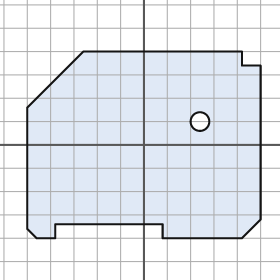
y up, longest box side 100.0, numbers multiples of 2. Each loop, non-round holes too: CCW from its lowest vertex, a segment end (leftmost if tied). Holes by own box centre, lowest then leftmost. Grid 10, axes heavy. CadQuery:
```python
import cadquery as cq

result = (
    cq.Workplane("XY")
    .moveTo(-46.0, -40.0)
    .lineTo(-38.0, -40.0)
    .lineTo(-38.0, -34.0)
    .lineTo(8.0, -34.0)
    .lineTo(8.0, -40.0)
    .lineTo(42.0, -40.0)
    .lineTo(50.0, -32.0)
    .lineTo(50.0, 34.0)
    .lineTo(42.0, 34.0)
    .lineTo(42.0, 40.0)
    .lineTo(-26.0, 40.0)
    .lineTo(-50.0, 16.0)
    .lineTo(-50.0, -36.0)
    .close()
    .moveTo(24.0, 10.0)
    .circle(4.0)
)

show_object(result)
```